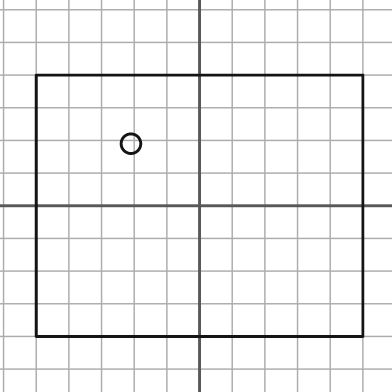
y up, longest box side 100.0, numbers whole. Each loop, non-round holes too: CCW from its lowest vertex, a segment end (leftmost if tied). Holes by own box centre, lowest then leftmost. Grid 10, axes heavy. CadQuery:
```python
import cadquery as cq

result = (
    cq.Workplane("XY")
    .moveTo(-50.0, -40.0)
    .lineTo(50.0, -40.0)
    .lineTo(50.0, 40.0)
    .lineTo(-50.0, 40.0)
    .close()
    .moveTo(-21.0, 19.0)
    .circle(3.0)
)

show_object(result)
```